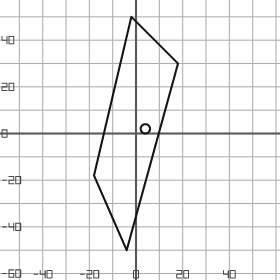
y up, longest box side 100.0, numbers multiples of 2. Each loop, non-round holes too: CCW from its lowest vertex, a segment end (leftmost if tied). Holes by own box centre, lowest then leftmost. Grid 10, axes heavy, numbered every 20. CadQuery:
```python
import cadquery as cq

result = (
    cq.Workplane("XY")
    .moveTo(-4.0, -50.0)
    .lineTo(18.0, 30.0)
    .lineTo(-2.0, 50.0)
    .lineTo(-18.0, -18.0)
    .close()
    .moveTo(4.0, 2.0)
    .circle(2.0)
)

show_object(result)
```